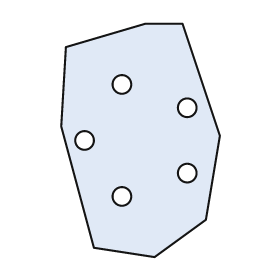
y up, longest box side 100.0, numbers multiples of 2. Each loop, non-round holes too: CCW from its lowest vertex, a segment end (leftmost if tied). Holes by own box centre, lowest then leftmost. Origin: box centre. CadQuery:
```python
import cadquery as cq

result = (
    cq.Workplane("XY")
    .moveTo(6.0, -50.0)
    .lineTo(28.0, -34.0)
    .lineTo(34.0, 2.0)
    .lineTo(18.0, 50.0)
    .lineTo(2.0, 50.0)
    .lineTo(-32.0, 40.0)
    .lineTo(-34.0, 6.0)
    .lineTo(-20.0, -46.0)
    .close()
    .moveTo(-8.0, -24.0)
    .circle(4.0)
    .moveTo(20.0, -14.0)
    .circle(4.0)
    .moveTo(-24.0, 0.0)
    .circle(4.0)
    .moveTo(20.0, 14.0)
    .circle(4.0)
    .moveTo(-8.0, 24.0)
    .circle(4.0)
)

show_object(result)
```